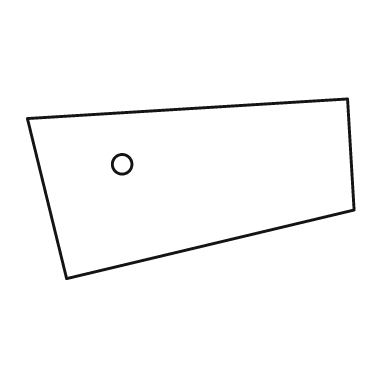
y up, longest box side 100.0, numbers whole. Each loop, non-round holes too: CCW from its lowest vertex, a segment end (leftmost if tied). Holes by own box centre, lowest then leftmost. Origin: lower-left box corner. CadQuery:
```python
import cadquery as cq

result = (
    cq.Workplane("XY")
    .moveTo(12.0, 0.0)
    .lineTo(100.0, 21.0)
    .lineTo(98.0, 55.0)
    .lineTo(0.0, 49.0)
    .close()
    .moveTo(29.0, 35.0)
    .circle(3.0)
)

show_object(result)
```